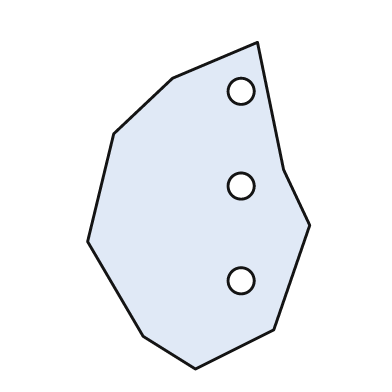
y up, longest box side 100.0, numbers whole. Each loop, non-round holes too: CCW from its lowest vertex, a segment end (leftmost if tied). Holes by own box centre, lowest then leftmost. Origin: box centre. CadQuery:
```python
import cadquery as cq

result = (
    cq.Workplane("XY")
    .moveTo(-1.0, -50.0)
    .lineTo(23.0, -38.0)
    .lineTo(34.0, -6.0)
    .lineTo(26.0, 11.0)
    .lineTo(18.0, 50.0)
    .lineTo(-8.0, 39.0)
    .lineTo(-26.0, 22.0)
    .lineTo(-34.0, -11.0)
    .lineTo(-17.0, -40.0)
    .close()
    .moveTo(13.0, -23.0)
    .circle(4.0)
    .moveTo(13.0, 6.0)
    .circle(4.0)
    .moveTo(13.0, 35.0)
    .circle(4.0)
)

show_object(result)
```